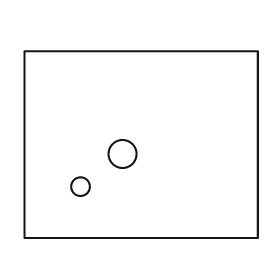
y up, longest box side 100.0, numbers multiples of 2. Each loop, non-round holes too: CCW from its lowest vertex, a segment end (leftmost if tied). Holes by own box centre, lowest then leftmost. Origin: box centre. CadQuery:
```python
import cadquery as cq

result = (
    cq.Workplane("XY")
    .moveTo(-50.0, -40.0)
    .lineTo(50.0, -40.0)
    .lineTo(50.0, 40.0)
    .lineTo(-50.0, 40.0)
    .close()
    .moveTo(-26.0, -18.0)
    .circle(4.0)
    .moveTo(-8.0, -4.0)
    .circle(6.0)
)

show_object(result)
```